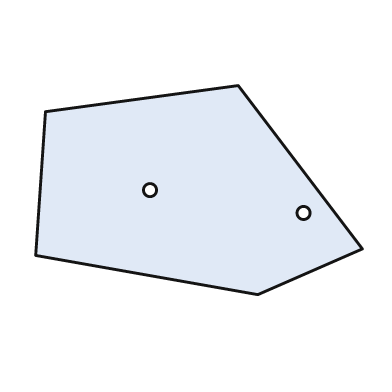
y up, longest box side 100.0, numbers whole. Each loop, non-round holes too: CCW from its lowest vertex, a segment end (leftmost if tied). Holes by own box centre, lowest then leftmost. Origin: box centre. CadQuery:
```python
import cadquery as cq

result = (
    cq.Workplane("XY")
    .moveTo(18.0, -32.0)
    .lineTo(50.0, -18.0)
    .lineTo(12.0, 32.0)
    .lineTo(-47.0, 24.0)
    .lineTo(-50.0, -20.0)
    .close()
    .moveTo(32.0, -7.0)
    .circle(2.0)
    .moveTo(-15.0, 0.0)
    .circle(2.0)
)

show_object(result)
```